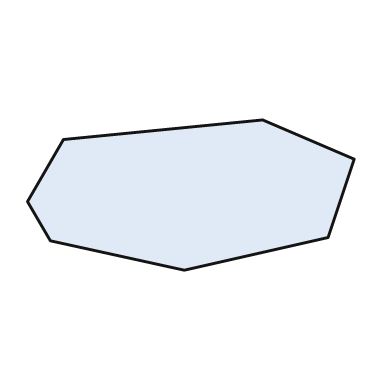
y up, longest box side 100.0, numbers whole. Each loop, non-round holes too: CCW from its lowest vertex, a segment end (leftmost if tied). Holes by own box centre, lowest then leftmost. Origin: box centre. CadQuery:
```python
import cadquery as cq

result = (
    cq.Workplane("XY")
    .moveTo(-2.0, -23.0)
    .lineTo(42.0, -13.0)
    .lineTo(50.0, 11.0)
    .lineTo(22.0, 23.0)
    .lineTo(-39.0, 17.0)
    .lineTo(-50.0, -2.0)
    .lineTo(-43.0, -14.0)
    .close()
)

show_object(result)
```